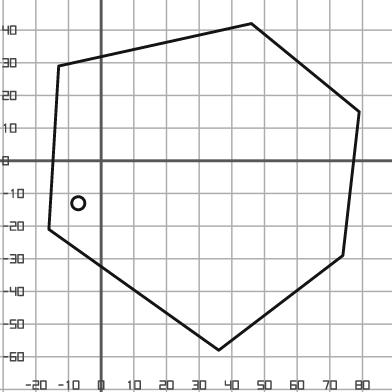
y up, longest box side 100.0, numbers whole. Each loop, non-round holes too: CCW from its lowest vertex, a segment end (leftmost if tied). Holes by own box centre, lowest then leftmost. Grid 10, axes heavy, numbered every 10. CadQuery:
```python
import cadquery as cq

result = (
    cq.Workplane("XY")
    .moveTo(36.0, -58.0)
    .lineTo(74.0, -29.0)
    .lineTo(79.0, 15.0)
    .lineTo(46.0, 42.0)
    .lineTo(-13.0, 29.0)
    .lineTo(-16.0, -21.0)
    .close()
    .moveTo(-7.0, -13.0)
    .circle(2.0)
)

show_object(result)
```